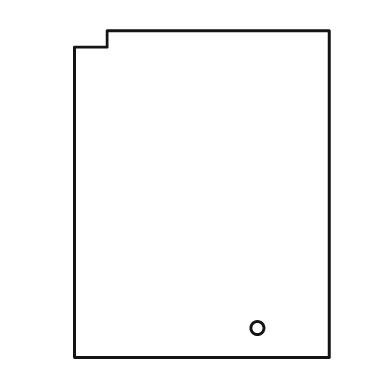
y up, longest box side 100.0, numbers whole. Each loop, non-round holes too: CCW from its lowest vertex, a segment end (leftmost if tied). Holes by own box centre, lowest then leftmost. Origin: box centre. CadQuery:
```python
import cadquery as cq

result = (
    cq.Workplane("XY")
    .moveTo(-39.0, -50.0)
    .lineTo(39.0, -50.0)
    .lineTo(39.0, 50.0)
    .lineTo(-29.0, 50.0)
    .lineTo(-29.0, 45.0)
    .lineTo(-39.0, 45.0)
    .close()
    .moveTo(17.0, -41.0)
    .circle(2.0)
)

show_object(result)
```